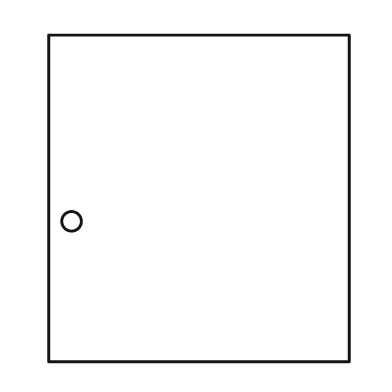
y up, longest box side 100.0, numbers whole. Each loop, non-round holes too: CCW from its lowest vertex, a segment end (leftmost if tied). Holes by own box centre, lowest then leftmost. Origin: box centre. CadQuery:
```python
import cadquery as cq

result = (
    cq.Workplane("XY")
    .moveTo(-46.0, -50.0)
    .lineTo(46.0, -50.0)
    .lineTo(46.0, 50.0)
    .lineTo(-46.0, 50.0)
    .close()
    .moveTo(-39.0, -7.0)
    .circle(3.0)
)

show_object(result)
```